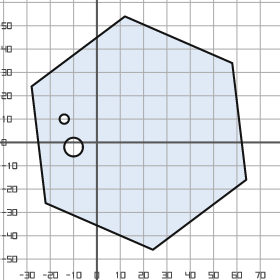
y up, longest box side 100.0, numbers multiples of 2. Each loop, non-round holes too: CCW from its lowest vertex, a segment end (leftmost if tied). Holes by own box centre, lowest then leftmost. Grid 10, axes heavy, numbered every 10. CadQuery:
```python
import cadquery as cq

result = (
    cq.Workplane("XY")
    .moveTo(24.0, -46.0)
    .lineTo(64.0, -16.0)
    .lineTo(58.0, 34.0)
    .lineTo(12.0, 54.0)
    .lineTo(-28.0, 24.0)
    .lineTo(-22.0, -26.0)
    .close()
    .moveTo(-10.0, -2.0)
    .circle(4.0)
    .moveTo(-14.0, 10.0)
    .circle(2.0)
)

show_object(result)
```